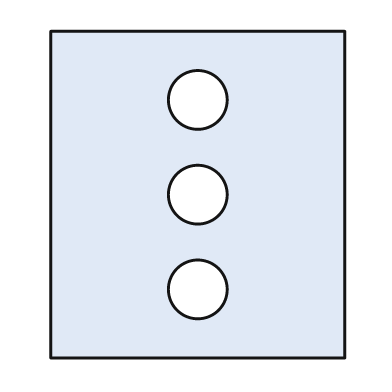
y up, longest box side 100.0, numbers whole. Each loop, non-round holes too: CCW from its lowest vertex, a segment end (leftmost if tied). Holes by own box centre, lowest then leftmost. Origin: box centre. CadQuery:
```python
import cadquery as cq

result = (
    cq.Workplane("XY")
    .moveTo(-45.0, -50.0)
    .lineTo(45.0, -50.0)
    .lineTo(45.0, 50.0)
    .lineTo(-45.0, 50.0)
    .close()
    .moveTo(0.0, -29.0)
    .circle(9.0)
    .moveTo(0.0, 0.0)
    .circle(9.0)
    .moveTo(0.0, 29.0)
    .circle(9.0)
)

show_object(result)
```